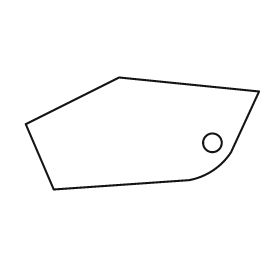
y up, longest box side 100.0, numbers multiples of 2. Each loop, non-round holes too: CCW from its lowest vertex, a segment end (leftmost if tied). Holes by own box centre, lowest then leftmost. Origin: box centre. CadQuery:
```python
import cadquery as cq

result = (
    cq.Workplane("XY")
    .moveTo(-38.0, -24.0)
    .lineTo(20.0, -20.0)
    .threePointArc((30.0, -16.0), (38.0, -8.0))
    .lineTo(50.0, 18.0)
    .lineTo(-10.0, 24.0)
    .lineTo(-50.0, 4.0)
    .close()
    .moveTo(30.0, -4.0)
    .circle(4.0)
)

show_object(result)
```